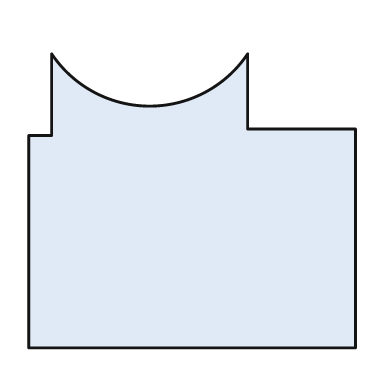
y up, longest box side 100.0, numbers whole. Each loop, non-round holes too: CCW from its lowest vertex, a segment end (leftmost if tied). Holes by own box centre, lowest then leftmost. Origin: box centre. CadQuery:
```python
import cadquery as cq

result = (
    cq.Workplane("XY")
    .moveTo(-50.0, -45.0)
    .lineTo(50.0, -45.0)
    .lineTo(50.0, 22.0)
    .lineTo(17.0, 22.0)
    .lineTo(17.0, 45.0)
    .threePointArc((-13.0, 29.0), (-43.0, 45.0))
    .lineTo(-43.0, 20.0)
    .lineTo(-50.0, 20.0)
    .close()
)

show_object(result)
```